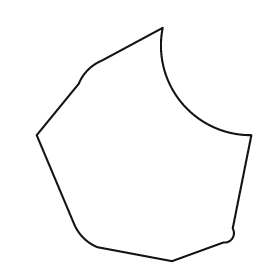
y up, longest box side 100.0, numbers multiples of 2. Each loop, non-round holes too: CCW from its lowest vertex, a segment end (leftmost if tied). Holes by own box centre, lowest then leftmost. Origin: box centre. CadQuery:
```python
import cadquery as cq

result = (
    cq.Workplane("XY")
    .moveTo(12.0, -50.0)
    .lineTo(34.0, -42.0)
    .threePointArc((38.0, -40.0), (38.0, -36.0))
    .lineTo(46.0, 4.0)
    .threePointArc((16.0, 18.0), (8.0, 50.0))
    .lineTo(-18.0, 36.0)
    .threePointArc((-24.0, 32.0), (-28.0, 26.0))
    .lineTo(-46.0, 4.0)
    .lineTo(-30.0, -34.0)
    .threePointArc((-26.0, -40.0), (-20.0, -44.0))
    .close()
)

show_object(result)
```